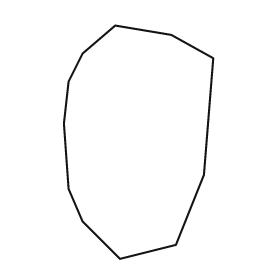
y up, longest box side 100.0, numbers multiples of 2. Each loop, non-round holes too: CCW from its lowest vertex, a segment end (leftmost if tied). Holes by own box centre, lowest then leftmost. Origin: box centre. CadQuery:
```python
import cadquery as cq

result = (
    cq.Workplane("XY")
    .moveTo(-8.0, -50.0)
    .lineTo(16.0, -44.0)
    .lineTo(28.0, -14.0)
    .lineTo(32.0, 36.0)
    .lineTo(14.0, 46.0)
    .lineTo(-10.0, 50.0)
    .lineTo(-24.0, 38.0)
    .lineTo(-30.0, 26.0)
    .lineTo(-32.0, 8.0)
    .lineTo(-30.0, -20.0)
    .lineTo(-24.0, -34.0)
    .close()
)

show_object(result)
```